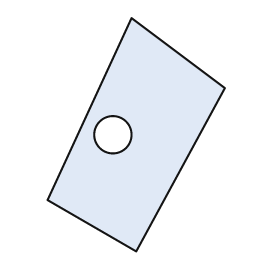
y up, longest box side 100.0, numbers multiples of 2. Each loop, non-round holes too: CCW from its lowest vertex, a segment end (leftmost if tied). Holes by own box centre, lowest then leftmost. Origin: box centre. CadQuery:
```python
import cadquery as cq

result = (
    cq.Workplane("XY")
    .moveTo(0.0, -50.0)
    .lineTo(38.0, 20.0)
    .lineTo(-2.0, 50.0)
    .lineTo(-38.0, -28.0)
    .close()
    .moveTo(-10.0, 0.0)
    .circle(8.0)
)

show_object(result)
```